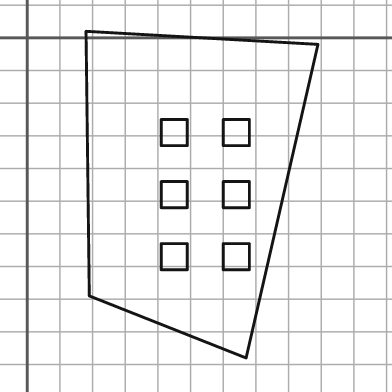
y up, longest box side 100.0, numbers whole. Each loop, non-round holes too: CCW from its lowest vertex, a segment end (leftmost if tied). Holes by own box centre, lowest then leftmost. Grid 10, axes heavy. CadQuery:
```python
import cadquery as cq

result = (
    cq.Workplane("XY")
    .moveTo(67.0, -98.0)
    .lineTo(89.0, -2.0)
    .lineTo(18.0, 2.0)
    .lineTo(19.0, -79.0)
    .close()
    .moveTo(41.0, -71.0)
    .lineTo(49.0, -71.0)
    .lineTo(49.0, -63.0)
    .lineTo(41.0, -63.0)
    .close()
    .moveTo(60.0, -71.0)
    .lineTo(68.0, -71.0)
    .lineTo(68.0, -63.0)
    .lineTo(60.0, -63.0)
    .close()
    .moveTo(41.0, -52.0)
    .lineTo(49.0, -52.0)
    .lineTo(49.0, -44.0)
    .lineTo(41.0, -44.0)
    .close()
    .moveTo(60.0, -52.0)
    .lineTo(68.0, -52.0)
    .lineTo(68.0, -44.0)
    .lineTo(60.0, -44.0)
    .close()
    .moveTo(41.0, -33.0)
    .lineTo(49.0, -33.0)
    .lineTo(49.0, -25.0)
    .lineTo(41.0, -25.0)
    .close()
    .moveTo(60.0, -33.0)
    .lineTo(68.0, -33.0)
    .lineTo(68.0, -25.0)
    .lineTo(60.0, -25.0)
    .close()
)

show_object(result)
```